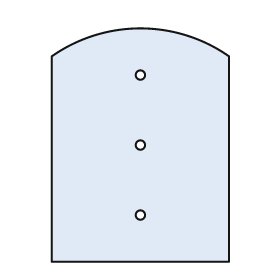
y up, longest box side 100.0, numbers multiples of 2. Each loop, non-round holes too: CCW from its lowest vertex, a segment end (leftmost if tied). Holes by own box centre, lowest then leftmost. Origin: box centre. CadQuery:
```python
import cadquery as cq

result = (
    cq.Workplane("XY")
    .moveTo(-38.0, -50.0)
    .lineTo(38.0, -50.0)
    .lineTo(38.0, 38.0)
    .threePointArc((0.0, 50.0), (-38.0, 38.0))
    .close()
    .moveTo(0.0, -30.0)
    .circle(2.0)
    .moveTo(0.0, 0.0)
    .circle(2.0)
    .moveTo(0.0, 30.0)
    .circle(2.0)
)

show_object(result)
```